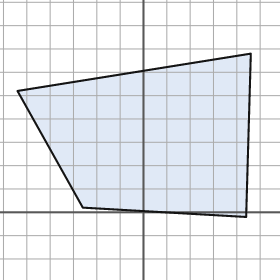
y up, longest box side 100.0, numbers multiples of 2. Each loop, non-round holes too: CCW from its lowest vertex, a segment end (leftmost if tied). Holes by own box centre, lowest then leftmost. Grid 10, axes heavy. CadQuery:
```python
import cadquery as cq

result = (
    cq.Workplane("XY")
    .moveTo(44.0, -2.0)
    .lineTo(46.0, 68.0)
    .lineTo(-54.0, 52.0)
    .lineTo(-26.0, 2.0)
    .close()
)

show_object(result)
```